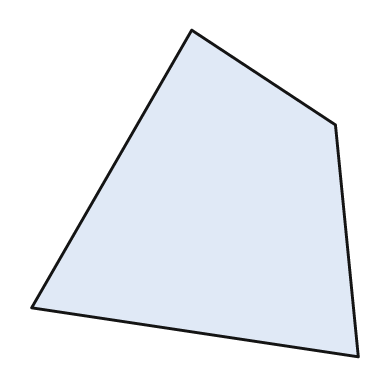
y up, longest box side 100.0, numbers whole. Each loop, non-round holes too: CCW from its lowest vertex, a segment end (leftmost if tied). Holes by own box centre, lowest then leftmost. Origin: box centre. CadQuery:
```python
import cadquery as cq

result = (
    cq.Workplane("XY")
    .moveTo(50.0, -50.0)
    .lineTo(43.0, 21.0)
    .lineTo(-1.0, 50.0)
    .lineTo(-50.0, -35.0)
    .close()
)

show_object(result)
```